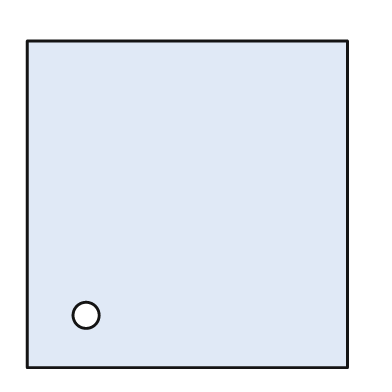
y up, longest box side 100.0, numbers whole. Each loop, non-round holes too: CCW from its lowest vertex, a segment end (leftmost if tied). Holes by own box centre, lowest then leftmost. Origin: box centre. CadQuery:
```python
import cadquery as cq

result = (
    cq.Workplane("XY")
    .moveTo(-49.0, -50.0)
    .lineTo(49.0, -50.0)
    .lineTo(49.0, 50.0)
    .lineTo(-49.0, 50.0)
    .close()
    .moveTo(-31.0, -34.0)
    .circle(4.0)
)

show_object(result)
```